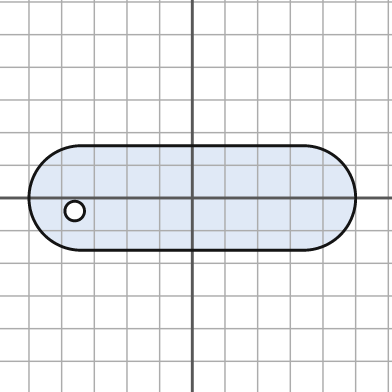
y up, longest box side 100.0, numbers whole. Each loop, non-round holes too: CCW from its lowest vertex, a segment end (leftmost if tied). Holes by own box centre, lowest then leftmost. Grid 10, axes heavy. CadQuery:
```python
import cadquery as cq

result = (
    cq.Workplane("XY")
    .moveTo(-34.0, -16.0)
    .lineTo(34.0, -16.0)
    .threePointArc((50.0, 0.0), (34.0, 16.0))
    .lineTo(-34.0, 16.0)
    .threePointArc((-50.0, 0.0), (-34.0, -16.0))
    .close()
    .moveTo(-36.0, -4.0)
    .circle(3.0)
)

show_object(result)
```